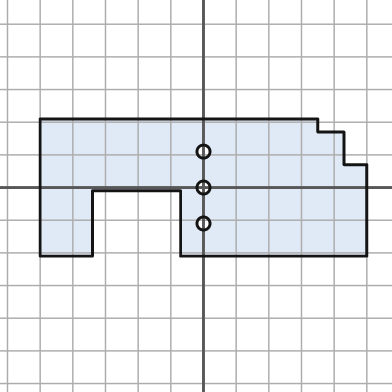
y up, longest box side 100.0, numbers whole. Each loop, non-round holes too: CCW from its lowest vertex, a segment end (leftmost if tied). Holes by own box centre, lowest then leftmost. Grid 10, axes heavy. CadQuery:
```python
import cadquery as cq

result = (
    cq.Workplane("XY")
    .moveTo(-50.0, -21.0)
    .lineTo(-34.0, -21.0)
    .lineTo(-34.0, -1.0)
    .lineTo(-7.0, -1.0)
    .lineTo(-7.0, -21.0)
    .lineTo(50.0, -21.0)
    .lineTo(50.0, 7.0)
    .lineTo(43.0, 7.0)
    .lineTo(43.0, 17.0)
    .lineTo(35.0, 17.0)
    .lineTo(35.0, 21.0)
    .lineTo(-50.0, 21.0)
    .close()
    .moveTo(0.0, -11.0)
    .circle(2.0)
    .moveTo(0.0, 0.0)
    .circle(2.0)
    .moveTo(0.0, 11.0)
    .circle(2.0)
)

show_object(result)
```